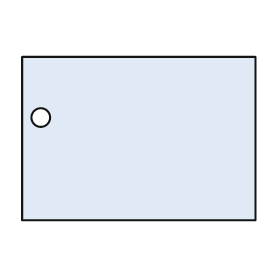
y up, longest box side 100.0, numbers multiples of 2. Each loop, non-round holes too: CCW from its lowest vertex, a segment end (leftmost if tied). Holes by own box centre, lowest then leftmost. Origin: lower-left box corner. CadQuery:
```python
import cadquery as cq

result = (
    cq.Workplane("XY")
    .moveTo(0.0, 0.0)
    .lineTo(100.0, 0.0)
    .lineTo(100.0, 70.0)
    .lineTo(0.0, 70.0)
    .close()
    .moveTo(8.0, 44.0)
    .circle(4.0)
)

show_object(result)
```